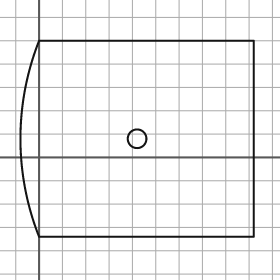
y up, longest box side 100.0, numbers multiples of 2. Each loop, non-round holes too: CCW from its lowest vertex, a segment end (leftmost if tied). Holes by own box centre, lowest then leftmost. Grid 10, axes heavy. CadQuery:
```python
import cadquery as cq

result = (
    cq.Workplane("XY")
    .moveTo(0.0, -34.0)
    .lineTo(92.0, -34.0)
    .lineTo(92.0, 50.0)
    .lineTo(0.0, 50.0)
    .threePointArc((-8.0, 8.0), (0.0, -34.0))
    .close()
    .moveTo(42.0, 8.0)
    .circle(4.0)
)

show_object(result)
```